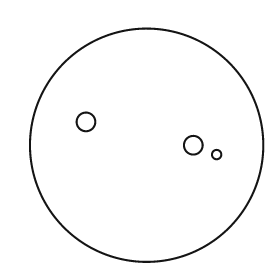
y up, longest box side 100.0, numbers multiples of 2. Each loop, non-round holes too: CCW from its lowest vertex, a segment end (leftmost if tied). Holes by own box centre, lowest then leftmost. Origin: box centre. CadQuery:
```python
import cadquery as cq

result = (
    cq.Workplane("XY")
    .moveTo(0.0, 0.0)
    .circle(50.0)
    .moveTo(30.0, -4.0)
    .circle(2.0)
    .moveTo(20.0, 0.0)
    .circle(4.0)
    .moveTo(-26.0, 10.0)
    .circle(4.0)
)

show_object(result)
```